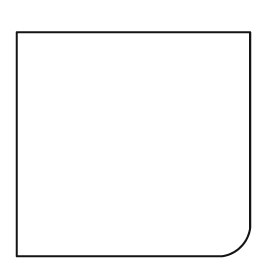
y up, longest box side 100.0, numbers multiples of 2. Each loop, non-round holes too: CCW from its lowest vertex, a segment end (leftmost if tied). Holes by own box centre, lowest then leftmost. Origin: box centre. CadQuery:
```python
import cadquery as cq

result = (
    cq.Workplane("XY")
    .moveTo(-50.0, -48.0)
    .lineTo(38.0, -48.0)
    .threePointArc((46.0, -44.0), (50.0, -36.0))
    .lineTo(50.0, 48.0)
    .lineTo(-50.0, 48.0)
    .close()
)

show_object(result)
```